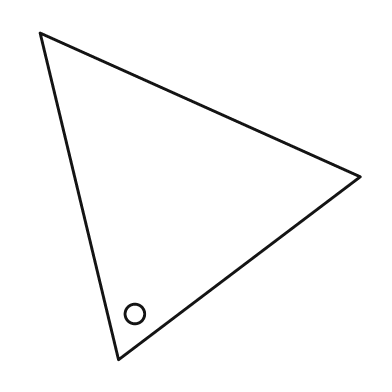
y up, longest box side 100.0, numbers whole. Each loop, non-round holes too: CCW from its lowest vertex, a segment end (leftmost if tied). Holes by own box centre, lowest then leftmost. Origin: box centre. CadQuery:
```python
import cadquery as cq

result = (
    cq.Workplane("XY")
    .moveTo(-25.0, -50.0)
    .lineTo(49.0, 6.0)
    .lineTo(-49.0, 50.0)
    .close()
    .moveTo(-20.0, -36.0)
    .circle(3.0)
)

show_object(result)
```